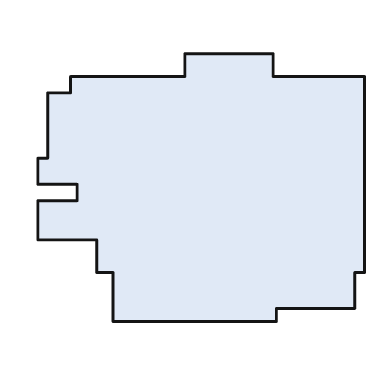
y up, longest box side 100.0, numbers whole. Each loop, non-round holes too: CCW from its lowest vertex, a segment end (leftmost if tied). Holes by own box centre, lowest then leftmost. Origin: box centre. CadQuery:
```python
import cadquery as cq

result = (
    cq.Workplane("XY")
    .moveTo(-27.0, -41.0)
    .lineTo(23.0, -41.0)
    .lineTo(23.0, -37.0)
    .lineTo(47.0, -37.0)
    .lineTo(47.0, -26.0)
    .lineTo(50.0, -26.0)
    .lineTo(50.0, 34.0)
    .lineTo(22.0, 34.0)
    .lineTo(22.0, 41.0)
    .lineTo(-5.0, 41.0)
    .lineTo(-5.0, 34.0)
    .lineTo(-40.0, 34.0)
    .lineTo(-40.0, 29.0)
    .lineTo(-47.0, 29.0)
    .lineTo(-47.0, 9.0)
    .lineTo(-50.0, 9.0)
    .lineTo(-50.0, 1.0)
    .lineTo(-38.0, 1.0)
    .lineTo(-38.0, -4.0)
    .lineTo(-50.0, -4.0)
    .lineTo(-50.0, -16.0)
    .lineTo(-32.0, -16.0)
    .lineTo(-32.0, -26.0)
    .lineTo(-27.0, -26.0)
    .close()
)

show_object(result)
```